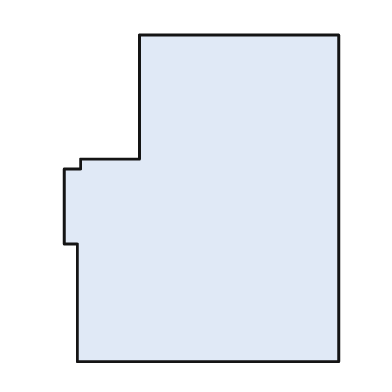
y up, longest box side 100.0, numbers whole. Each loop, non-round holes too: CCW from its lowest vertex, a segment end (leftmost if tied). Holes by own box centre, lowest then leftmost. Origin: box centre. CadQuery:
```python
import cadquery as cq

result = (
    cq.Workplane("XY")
    .moveTo(-38.0, -50.0)
    .lineTo(42.0, -50.0)
    .lineTo(42.0, 50.0)
    .lineTo(-19.0, 50.0)
    .lineTo(-19.0, 12.0)
    .lineTo(-37.0, 12.0)
    .lineTo(-37.0, 9.0)
    .lineTo(-42.0, 9.0)
    .lineTo(-42.0, -14.0)
    .lineTo(-38.0, -14.0)
    .close()
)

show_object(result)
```